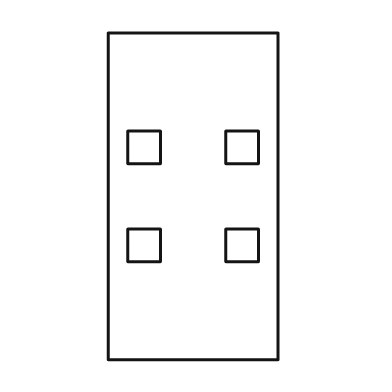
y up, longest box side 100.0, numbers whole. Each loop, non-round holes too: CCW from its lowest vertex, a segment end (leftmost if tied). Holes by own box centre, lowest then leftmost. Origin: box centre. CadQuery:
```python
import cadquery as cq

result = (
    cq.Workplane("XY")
    .moveTo(-26.0, -50.0)
    .lineTo(26.0, -50.0)
    .lineTo(26.0, 50.0)
    .lineTo(-26.0, 50.0)
    .close()
    .moveTo(-20.0, -20.0)
    .lineTo(-10.0, -20.0)
    .lineTo(-10.0, -10.0)
    .lineTo(-20.0, -10.0)
    .close()
    .moveTo(10.0, -20.0)
    .lineTo(20.0, -20.0)
    .lineTo(20.0, -10.0)
    .lineTo(10.0, -10.0)
    .close()
    .moveTo(-20.0, 10.0)
    .lineTo(-10.0, 10.0)
    .lineTo(-10.0, 20.0)
    .lineTo(-20.0, 20.0)
    .close()
    .moveTo(10.0, 10.0)
    .lineTo(20.0, 10.0)
    .lineTo(20.0, 20.0)
    .lineTo(10.0, 20.0)
    .close()
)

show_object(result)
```